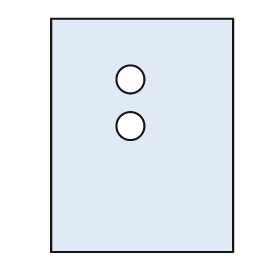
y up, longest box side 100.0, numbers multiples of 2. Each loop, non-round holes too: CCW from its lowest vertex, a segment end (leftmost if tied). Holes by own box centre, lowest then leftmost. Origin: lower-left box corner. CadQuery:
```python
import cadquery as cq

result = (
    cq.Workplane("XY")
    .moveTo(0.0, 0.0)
    .lineTo(78.0, 0.0)
    .lineTo(78.0, 100.0)
    .lineTo(0.0, 100.0)
    .close()
    .moveTo(34.0, 54.0)
    .circle(6.0)
    .moveTo(34.0, 74.0)
    .circle(6.0)
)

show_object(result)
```